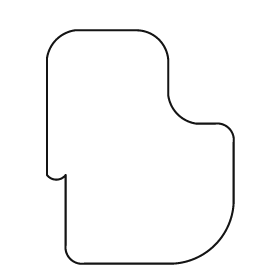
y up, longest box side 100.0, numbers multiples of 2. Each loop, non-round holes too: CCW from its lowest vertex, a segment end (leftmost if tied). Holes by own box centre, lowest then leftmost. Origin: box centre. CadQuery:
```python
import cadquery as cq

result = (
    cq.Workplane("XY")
    .moveTo(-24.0, -50.0)
    .lineTo(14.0, -50.0)
    .threePointArc((32.0, -42.0), (40.0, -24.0))
    .lineTo(40.0, 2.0)
    .threePointArc((38.0, 8.0), (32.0, 10.0))
    .lineTo(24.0, 10.0)
    .threePointArc((16.0, 14.0), (12.0, 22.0))
    .lineTo(12.0, 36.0)
    .threePointArc((8.0, 46.0), (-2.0, 50.0))
    .lineTo(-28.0, 50.0)
    .threePointArc((-36.0, 46.0), (-40.0, 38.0))
    .lineTo(-40.0, -12.0)
    .threePointArc((-36.0, -14.0), (-32.0, -12.0))
    .lineTo(-32.0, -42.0)
    .threePointArc((-30.0, -48.0), (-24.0, -50.0))
    .close()
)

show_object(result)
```